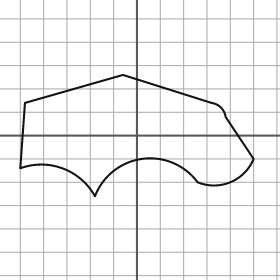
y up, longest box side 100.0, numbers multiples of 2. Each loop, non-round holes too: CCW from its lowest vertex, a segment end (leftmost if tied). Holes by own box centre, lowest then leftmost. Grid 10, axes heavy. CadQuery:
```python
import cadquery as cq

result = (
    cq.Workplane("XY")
    .moveTo(-18.0, -26.0)
    .threePointArc((2.0, -10.0), (26.0, -20.0))
    .threePointArc((40.0, -20.0), (50.0, -10.0))
    .lineTo(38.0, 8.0)
    .threePointArc((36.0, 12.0), (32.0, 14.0))
    .lineTo(-6.0, 26.0)
    .lineTo(-48.0, 14.0)
    .lineTo(-50.0, -14.0)
    .threePointArc((-32.0, -14.0), (-18.0, -26.0))
    .close()
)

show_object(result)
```